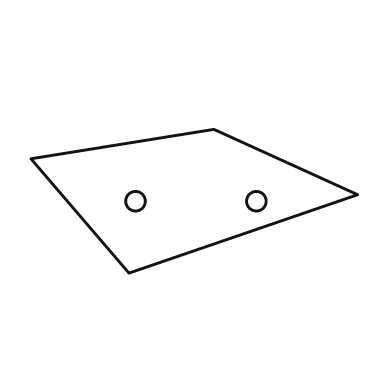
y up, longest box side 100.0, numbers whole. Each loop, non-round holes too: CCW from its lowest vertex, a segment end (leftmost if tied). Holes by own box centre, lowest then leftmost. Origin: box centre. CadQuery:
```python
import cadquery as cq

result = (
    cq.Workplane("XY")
    .moveTo(-20.0, -22.0)
    .lineTo(50.0, 2.0)
    .lineTo(6.0, 22.0)
    .lineTo(-50.0, 13.0)
    .close()
    .moveTo(-18.0, 0.0)
    .circle(3.0)
    .moveTo(19.0, 0.0)
    .circle(3.0)
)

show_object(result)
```